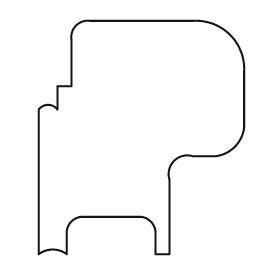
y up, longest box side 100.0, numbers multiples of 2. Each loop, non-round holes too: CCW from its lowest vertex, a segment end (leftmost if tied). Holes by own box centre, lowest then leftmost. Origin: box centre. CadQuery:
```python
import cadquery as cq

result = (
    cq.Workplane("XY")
    .moveTo(-44.0, -50.0)
    .threePointArc((-38.0, -48.0), (-32.0, -50.0))
    .lineTo(-32.0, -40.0)
    .threePointArc((-30.0, -36.0), (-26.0, -34.0))
    .lineTo(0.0, -34.0)
    .threePointArc((4.0, -36.0), (6.0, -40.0))
    .lineTo(6.0, -50.0)
    .lineTo(12.0, -50.0)
    .lineTo(12.0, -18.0)
    .threePointArc((14.0, -10.0), (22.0, -8.0))
    .lineTo(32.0, -8.0)
    .threePointArc((40.0, -4.0), (44.0, 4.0))
    .lineTo(44.0, 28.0)
    .threePointArc((38.0, 44.0), (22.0, 50.0))
    .lineTo(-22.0, 50.0)
    .threePointArc((-28.0, 48.0), (-30.0, 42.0))
    .lineTo(-30.0, 22.0)
    .lineTo(-36.0, 22.0)
    .lineTo(-36.0, 12.0)
    .threePointArc((-40.0, 14.0), (-44.0, 12.0))
    .close()
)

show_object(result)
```